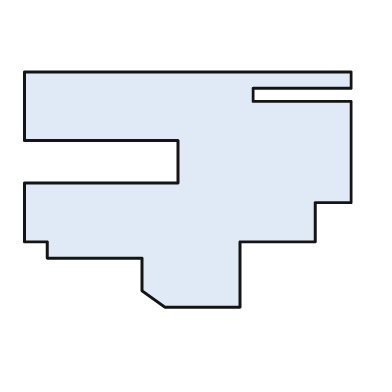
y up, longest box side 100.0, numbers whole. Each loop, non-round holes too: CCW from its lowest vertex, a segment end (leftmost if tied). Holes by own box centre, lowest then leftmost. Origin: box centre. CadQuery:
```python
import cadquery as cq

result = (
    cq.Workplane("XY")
    .moveTo(-7.0, -36.0)
    .lineTo(16.0, -36.0)
    .lineTo(16.0, -16.0)
    .lineTo(39.0, -16.0)
    .lineTo(39.0, -4.0)
    .lineTo(50.0, -4.0)
    .lineTo(50.0, 27.0)
    .lineTo(20.0, 27.0)
    .lineTo(20.0, 31.0)
    .lineTo(50.0, 31.0)
    .lineTo(50.0, 36.0)
    .lineTo(-50.0, 36.0)
    .lineTo(-50.0, 15.0)
    .lineTo(-3.0, 15.0)
    .lineTo(-3.0, 2.0)
    .lineTo(-50.0, 2.0)
    .lineTo(-50.0, -16.0)
    .lineTo(-43.0, -16.0)
    .lineTo(-43.0, -21.0)
    .lineTo(-14.0, -21.0)
    .lineTo(-14.0, -31.0)
    .close()
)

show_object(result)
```